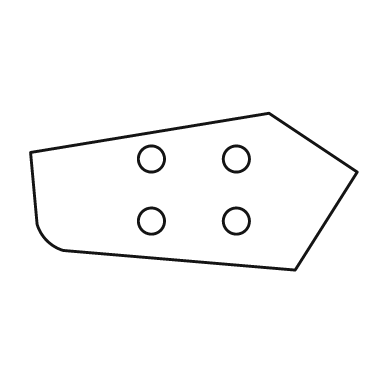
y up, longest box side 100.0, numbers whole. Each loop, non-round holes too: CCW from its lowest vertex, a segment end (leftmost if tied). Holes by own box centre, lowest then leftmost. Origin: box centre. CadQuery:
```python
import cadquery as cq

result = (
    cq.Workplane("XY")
    .moveTo(31.0, -24.0)
    .lineTo(50.0, 6.0)
    .lineTo(23.0, 24.0)
    .lineTo(-50.0, 12.0)
    .lineTo(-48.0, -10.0)
    .threePointArc((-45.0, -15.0), (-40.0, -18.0))
    .close()
    .moveTo(-13.0, -9.0)
    .circle(4.0)
    .moveTo(13.0, -9.0)
    .circle(4.0)
    .moveTo(-13.0, 10.0)
    .circle(4.0)
    .moveTo(13.0, 10.0)
    .circle(4.0)
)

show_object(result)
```